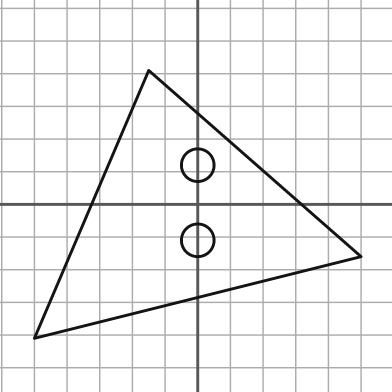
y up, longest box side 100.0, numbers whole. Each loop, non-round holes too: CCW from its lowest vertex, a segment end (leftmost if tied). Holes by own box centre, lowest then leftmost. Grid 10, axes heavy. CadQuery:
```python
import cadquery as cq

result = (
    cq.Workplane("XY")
    .moveTo(-50.0, -41.0)
    .lineTo(50.0, -16.0)
    .lineTo(-15.0, 41.0)
    .close()
    .moveTo(0.0, -11.0)
    .circle(5.0)
    .moveTo(0.0, 12.0)
    .circle(5.0)
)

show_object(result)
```